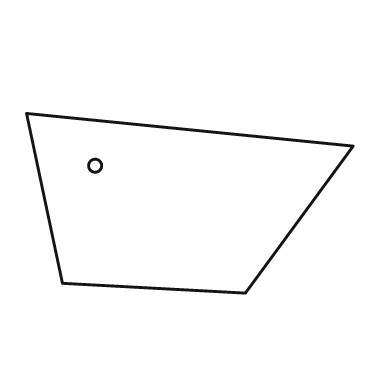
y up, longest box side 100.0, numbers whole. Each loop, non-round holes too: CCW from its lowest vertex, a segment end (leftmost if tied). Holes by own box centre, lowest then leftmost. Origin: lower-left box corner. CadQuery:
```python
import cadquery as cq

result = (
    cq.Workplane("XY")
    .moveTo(67.0, 0.0)
    .lineTo(100.0, 45.0)
    .lineTo(0.0, 55.0)
    .lineTo(11.0, 3.0)
    .close()
    .moveTo(21.0, 39.0)
    .circle(2.0)
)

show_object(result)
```